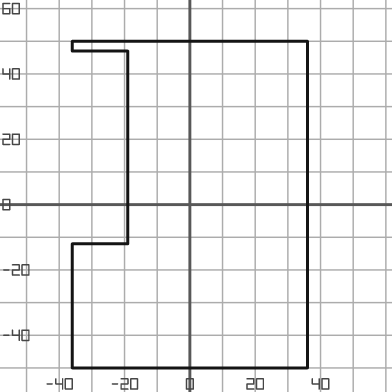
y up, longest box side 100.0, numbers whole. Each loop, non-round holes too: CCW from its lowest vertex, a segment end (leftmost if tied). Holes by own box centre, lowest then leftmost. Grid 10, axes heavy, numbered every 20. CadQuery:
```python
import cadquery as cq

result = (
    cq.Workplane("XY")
    .moveTo(-36.0, -50.0)
    .lineTo(36.0, -50.0)
    .lineTo(36.0, 50.0)
    .lineTo(-36.0, 50.0)
    .lineTo(-36.0, 47.0)
    .lineTo(-19.0, 47.0)
    .lineTo(-19.0, -12.0)
    .lineTo(-36.0, -12.0)
    .close()
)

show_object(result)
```